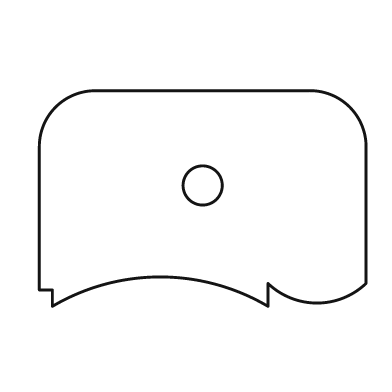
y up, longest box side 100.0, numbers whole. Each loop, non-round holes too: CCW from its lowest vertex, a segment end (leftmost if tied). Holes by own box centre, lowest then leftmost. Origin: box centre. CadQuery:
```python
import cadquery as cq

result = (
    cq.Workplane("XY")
    .moveTo(-46.0, -33.0)
    .threePointArc((-13.0, -24.0), (20.0, -33.0))
    .lineTo(20.0, -26.0)
    .threePointArc((35.0, -32.0), (50.0, -26.0))
    .lineTo(50.0, 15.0)
    .threePointArc((45.0, 28.0), (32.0, 33.0))
    .lineTo(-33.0, 33.0)
    .threePointArc((-45.0, 28.0), (-50.0, 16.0))
    .lineTo(-50.0, -28.0)
    .lineTo(-46.0, -28.0)
    .close()
    .moveTo(0.0, 4.0)
    .circle(6.0)
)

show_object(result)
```